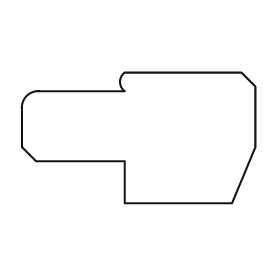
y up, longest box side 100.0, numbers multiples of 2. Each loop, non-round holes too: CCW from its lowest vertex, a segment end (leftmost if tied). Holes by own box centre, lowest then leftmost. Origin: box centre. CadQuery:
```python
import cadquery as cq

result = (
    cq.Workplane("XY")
    .moveTo(-6.0, -28.0)
    .lineTo(40.0, -28.0)
    .lineTo(50.0, -4.0)
    .lineTo(50.0, 22.0)
    .lineTo(44.0, 28.0)
    .lineTo(-6.0, 28.0)
    .threePointArc((-8.0, 24.0), (-6.0, 20.0))
    .lineTo(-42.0, 20.0)
    .threePointArc((-48.0, 18.0), (-50.0, 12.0))
    .lineTo(-50.0, -4.0)
    .lineTo(-44.0, -10.0)
    .lineTo(-6.0, -10.0)
    .close()
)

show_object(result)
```